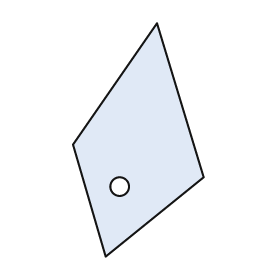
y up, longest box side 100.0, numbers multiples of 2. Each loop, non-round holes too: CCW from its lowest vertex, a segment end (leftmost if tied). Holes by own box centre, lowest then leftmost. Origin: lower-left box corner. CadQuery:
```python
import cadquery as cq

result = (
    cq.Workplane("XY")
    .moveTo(14.0, 0.0)
    .lineTo(56.0, 34.0)
    .lineTo(36.0, 100.0)
    .lineTo(0.0, 48.0)
    .close()
    .moveTo(20.0, 30.0)
    .circle(4.0)
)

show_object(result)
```